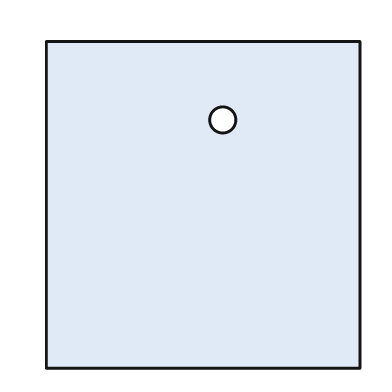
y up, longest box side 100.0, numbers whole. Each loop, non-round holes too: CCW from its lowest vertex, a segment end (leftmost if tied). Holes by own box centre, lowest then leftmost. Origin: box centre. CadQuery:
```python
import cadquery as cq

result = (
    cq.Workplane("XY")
    .moveTo(-48.0, -50.0)
    .lineTo(48.0, -50.0)
    .lineTo(48.0, 50.0)
    .lineTo(-48.0, 50.0)
    .close()
    .moveTo(6.0, 26.0)
    .circle(4.0)
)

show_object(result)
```